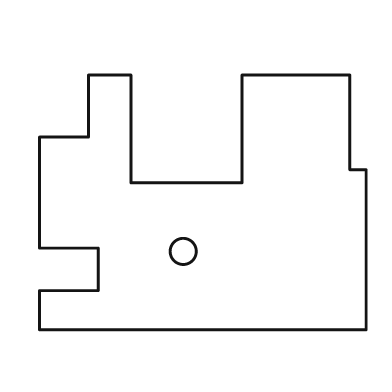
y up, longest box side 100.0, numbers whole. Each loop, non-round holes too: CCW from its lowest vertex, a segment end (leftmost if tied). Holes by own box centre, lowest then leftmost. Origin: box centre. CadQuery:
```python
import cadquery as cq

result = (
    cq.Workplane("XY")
    .moveTo(-50.0, -39.0)
    .lineTo(50.0, -39.0)
    .lineTo(50.0, 10.0)
    .lineTo(45.0, 10.0)
    .lineTo(45.0, 39.0)
    .lineTo(12.0, 39.0)
    .lineTo(12.0, 6.0)
    .lineTo(-22.0, 6.0)
    .lineTo(-22.0, 39.0)
    .lineTo(-35.0, 39.0)
    .lineTo(-35.0, 20.0)
    .lineTo(-50.0, 20.0)
    .lineTo(-50.0, -14.0)
    .lineTo(-32.0, -14.0)
    .lineTo(-32.0, -27.0)
    .lineTo(-50.0, -27.0)
    .close()
    .moveTo(-6.0, -15.0)
    .circle(4.0)
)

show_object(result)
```